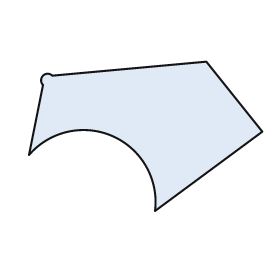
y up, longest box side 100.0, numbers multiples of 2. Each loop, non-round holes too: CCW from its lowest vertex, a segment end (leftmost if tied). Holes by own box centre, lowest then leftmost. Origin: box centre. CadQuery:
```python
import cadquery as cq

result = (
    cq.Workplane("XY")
    .moveTo(4.0, -32.0)
    .lineTo(50.0, 2.0)
    .lineTo(26.0, 32.0)
    .lineTo(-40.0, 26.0)
    .threePointArc((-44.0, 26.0), (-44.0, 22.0))
    .lineTo(-50.0, -8.0)
    .threePointArc((-14.0, 0.0), (4.0, -32.0))
    .close()
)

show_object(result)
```